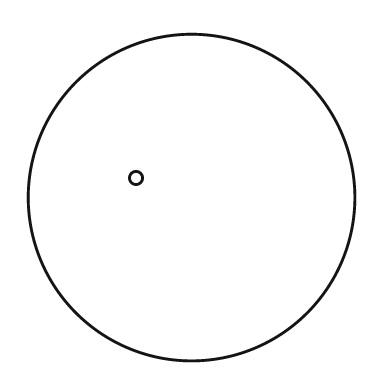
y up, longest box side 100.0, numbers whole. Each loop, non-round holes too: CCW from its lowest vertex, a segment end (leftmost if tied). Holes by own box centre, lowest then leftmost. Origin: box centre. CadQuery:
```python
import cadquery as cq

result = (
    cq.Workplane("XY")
    .moveTo(0.0, 0.0)
    .circle(50.0)
    .moveTo(-17.0, 6.0)
    .circle(2.0)
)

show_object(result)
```